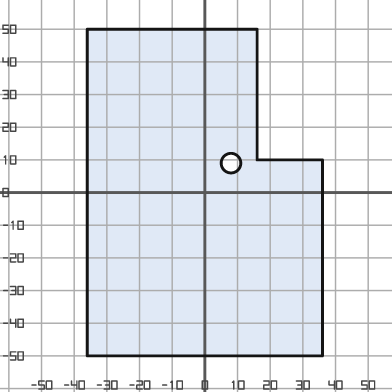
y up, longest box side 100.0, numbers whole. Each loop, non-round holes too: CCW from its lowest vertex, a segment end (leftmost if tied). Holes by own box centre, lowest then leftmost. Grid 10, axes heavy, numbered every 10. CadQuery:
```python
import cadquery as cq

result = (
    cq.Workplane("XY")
    .moveTo(-36.0, -50.0)
    .lineTo(36.0, -50.0)
    .lineTo(36.0, 10.0)
    .lineTo(16.0, 10.0)
    .lineTo(16.0, 50.0)
    .lineTo(-36.0, 50.0)
    .close()
    .moveTo(8.0, 9.0)
    .circle(3.0)
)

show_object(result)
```